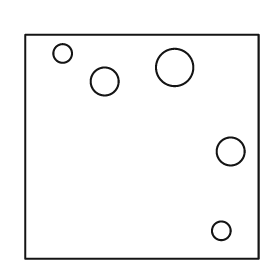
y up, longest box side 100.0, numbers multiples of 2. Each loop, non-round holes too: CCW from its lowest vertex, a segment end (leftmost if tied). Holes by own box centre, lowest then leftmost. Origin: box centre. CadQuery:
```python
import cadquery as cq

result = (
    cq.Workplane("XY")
    .moveTo(-50.0, -48.0)
    .lineTo(50.0, -48.0)
    .lineTo(50.0, 48.0)
    .lineTo(-50.0, 48.0)
    .close()
    .moveTo(34.0, -36.0)
    .circle(4.0)
    .moveTo(38.0, -2.0)
    .circle(6.0)
    .moveTo(-16.0, 28.0)
    .circle(6.0)
    .moveTo(14.0, 34.0)
    .circle(8.0)
    .moveTo(-34.0, 40.0)
    .circle(4.0)
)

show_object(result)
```